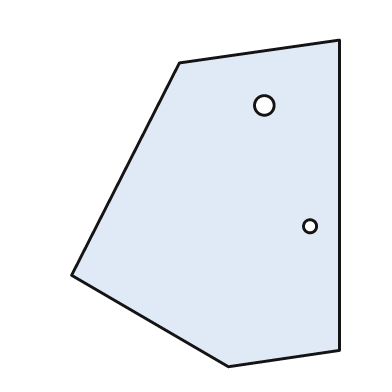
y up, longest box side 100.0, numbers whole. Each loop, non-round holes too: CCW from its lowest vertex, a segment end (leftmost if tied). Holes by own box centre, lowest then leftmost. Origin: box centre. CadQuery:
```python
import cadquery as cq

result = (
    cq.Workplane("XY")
    .moveTo(7.0, -50.0)
    .lineTo(41.0, -45.0)
    .lineTo(41.0, 50.0)
    .lineTo(-8.0, 43.0)
    .lineTo(-41.0, -22.0)
    .close()
    .moveTo(32.0, -7.0)
    .circle(2.0)
    .moveTo(18.0, 30.0)
    .circle(3.0)
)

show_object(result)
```